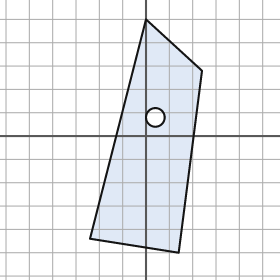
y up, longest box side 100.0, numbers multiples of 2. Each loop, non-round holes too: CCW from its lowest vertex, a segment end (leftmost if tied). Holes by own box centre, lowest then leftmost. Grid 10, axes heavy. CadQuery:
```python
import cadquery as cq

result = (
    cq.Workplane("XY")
    .moveTo(14.0, -50.0)
    .lineTo(24.0, 28.0)
    .lineTo(0.0, 50.0)
    .lineTo(-24.0, -44.0)
    .close()
    .moveTo(4.0, 8.0)
    .circle(4.0)
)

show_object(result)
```